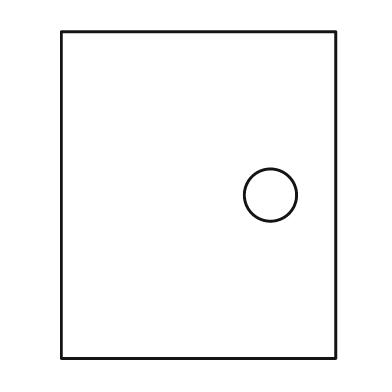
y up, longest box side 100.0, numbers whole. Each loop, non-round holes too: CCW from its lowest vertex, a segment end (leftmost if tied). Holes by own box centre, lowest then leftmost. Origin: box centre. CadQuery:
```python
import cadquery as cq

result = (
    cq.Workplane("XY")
    .moveTo(-42.0, -50.0)
    .lineTo(42.0, -50.0)
    .lineTo(42.0, 50.0)
    .lineTo(-42.0, 50.0)
    .close()
    .moveTo(22.0, 0.0)
    .circle(8.0)
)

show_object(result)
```